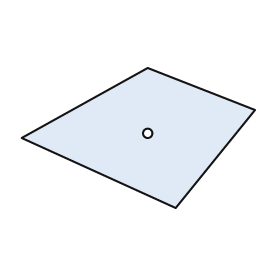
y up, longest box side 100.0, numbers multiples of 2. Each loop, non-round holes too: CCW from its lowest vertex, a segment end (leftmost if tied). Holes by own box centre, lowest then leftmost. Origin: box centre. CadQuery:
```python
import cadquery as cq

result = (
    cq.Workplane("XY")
    .moveTo(16.0, -30.0)
    .lineTo(50.0, 12.0)
    .lineTo(4.0, 30.0)
    .lineTo(-50.0, 0.0)
    .close()
    .moveTo(4.0, 2.0)
    .circle(2.0)
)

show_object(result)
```